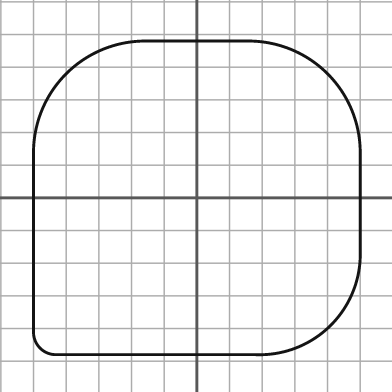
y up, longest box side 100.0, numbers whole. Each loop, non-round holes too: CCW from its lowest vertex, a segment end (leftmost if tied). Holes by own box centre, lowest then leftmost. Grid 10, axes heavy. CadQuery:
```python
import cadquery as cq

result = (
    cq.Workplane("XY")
    .moveTo(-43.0, -48.0)
    .lineTo(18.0, -48.0)
    .threePointArc((41.0, -39.0), (50.0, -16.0))
    .lineTo(50.0, 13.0)
    .threePointArc((40.0, 38.0), (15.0, 48.0))
    .lineTo(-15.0, 48.0)
    .threePointArc((-40.0, 38.0), (-50.0, 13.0))
    .lineTo(-50.0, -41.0)
    .threePointArc((-48.0, -46.0), (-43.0, -48.0))
    .close()
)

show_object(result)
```